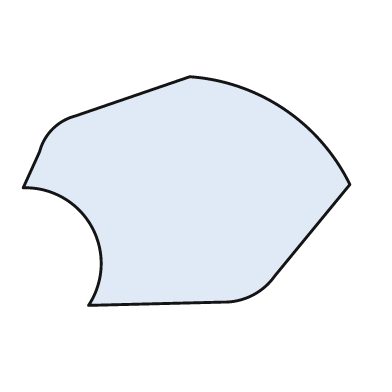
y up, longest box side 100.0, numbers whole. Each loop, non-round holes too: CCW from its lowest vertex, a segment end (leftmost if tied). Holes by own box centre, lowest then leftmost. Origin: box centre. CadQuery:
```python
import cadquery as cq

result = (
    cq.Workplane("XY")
    .moveTo(-30.0, -35.0)
    .lineTo(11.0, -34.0)
    .threePointArc((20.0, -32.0), (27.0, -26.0))
    .lineTo(50.0, 2.0)
    .threePointArc((30.0, 25.0), (1.0, 35.0))
    .lineTo(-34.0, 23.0)
    .threePointArc((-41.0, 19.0), (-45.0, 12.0))
    .lineTo(-50.0, 1.0)
    .threePointArc((-29.0, -11.0), (-30.0, -35.0))
    .close()
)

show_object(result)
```